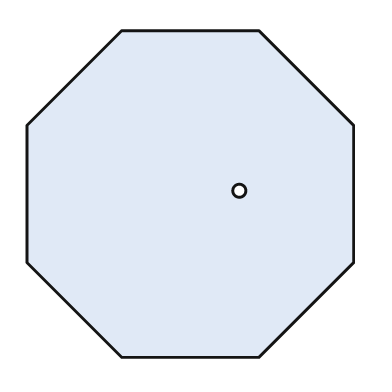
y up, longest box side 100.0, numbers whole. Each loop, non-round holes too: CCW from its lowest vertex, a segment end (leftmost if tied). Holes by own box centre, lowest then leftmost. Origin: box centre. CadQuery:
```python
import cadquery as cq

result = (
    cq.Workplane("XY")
    .moveTo(-21.0, -50.0)
    .lineTo(21.0, -50.0)
    .lineTo(50.0, -21.0)
    .lineTo(50.0, 21.0)
    .lineTo(21.0, 50.0)
    .lineTo(-21.0, 50.0)
    .lineTo(-50.0, 21.0)
    .lineTo(-50.0, -21.0)
    .close()
    .moveTo(15.0, 1.0)
    .circle(2.0)
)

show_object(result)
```